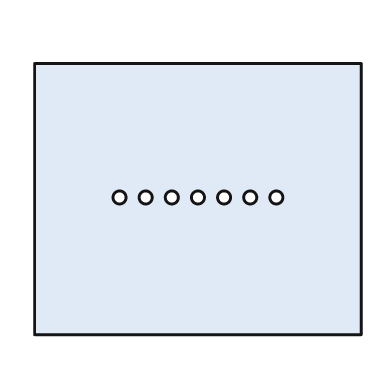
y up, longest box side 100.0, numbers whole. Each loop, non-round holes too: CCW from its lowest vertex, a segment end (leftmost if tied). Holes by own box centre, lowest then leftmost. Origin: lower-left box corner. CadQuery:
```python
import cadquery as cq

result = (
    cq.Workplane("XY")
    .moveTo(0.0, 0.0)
    .lineTo(100.0, 0.0)
    .lineTo(100.0, 83.0)
    .lineTo(0.0, 83.0)
    .close()
    .moveTo(26.0, 42.0)
    .circle(2.0)
    .moveTo(34.0, 42.0)
    .circle(2.0)
    .moveTo(42.0, 42.0)
    .circle(2.0)
    .moveTo(50.0, 42.0)
    .circle(2.0)
    .moveTo(58.0, 42.0)
    .circle(2.0)
    .moveTo(66.0, 42.0)
    .circle(2.0)
    .moveTo(74.0, 42.0)
    .circle(2.0)
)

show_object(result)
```